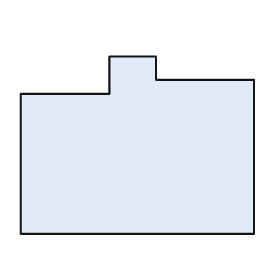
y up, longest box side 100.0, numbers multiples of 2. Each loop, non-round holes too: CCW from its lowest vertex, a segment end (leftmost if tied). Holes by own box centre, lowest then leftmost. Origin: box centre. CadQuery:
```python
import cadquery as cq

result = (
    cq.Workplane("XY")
    .moveTo(-50.0, -38.0)
    .lineTo(50.0, -38.0)
    .lineTo(50.0, 28.0)
    .lineTo(8.0, 28.0)
    .lineTo(8.0, 38.0)
    .lineTo(-12.0, 38.0)
    .lineTo(-12.0, 22.0)
    .lineTo(-50.0, 22.0)
    .close()
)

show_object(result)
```